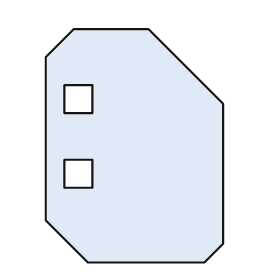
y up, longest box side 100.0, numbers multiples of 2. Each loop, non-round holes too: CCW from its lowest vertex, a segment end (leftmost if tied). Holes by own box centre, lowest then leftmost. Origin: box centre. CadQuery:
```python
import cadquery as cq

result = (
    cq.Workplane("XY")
    .moveTo(-20.0, -50.0)
    .lineTo(30.0, -50.0)
    .lineTo(38.0, -42.0)
    .lineTo(38.0, 18.0)
    .lineTo(6.0, 50.0)
    .lineTo(-26.0, 50.0)
    .lineTo(-38.0, 38.0)
    .lineTo(-38.0, -32.0)
    .close()
    .moveTo(-30.0, -18.0)
    .lineTo(-18.0, -18.0)
    .lineTo(-18.0, -6.0)
    .lineTo(-30.0, -6.0)
    .close()
    .moveTo(-30.0, 14.0)
    .lineTo(-18.0, 14.0)
    .lineTo(-18.0, 26.0)
    .lineTo(-30.0, 26.0)
    .close()
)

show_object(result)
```